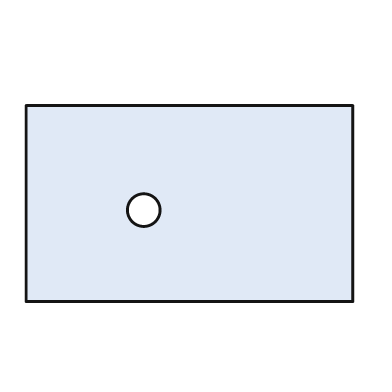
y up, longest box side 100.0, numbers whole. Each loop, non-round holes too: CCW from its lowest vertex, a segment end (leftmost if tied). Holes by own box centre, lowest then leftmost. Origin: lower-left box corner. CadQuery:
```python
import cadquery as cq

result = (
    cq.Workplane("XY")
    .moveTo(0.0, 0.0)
    .lineTo(100.0, 0.0)
    .lineTo(100.0, 60.0)
    .lineTo(0.0, 60.0)
    .close()
    .moveTo(36.0, 28.0)
    .circle(5.0)
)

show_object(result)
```